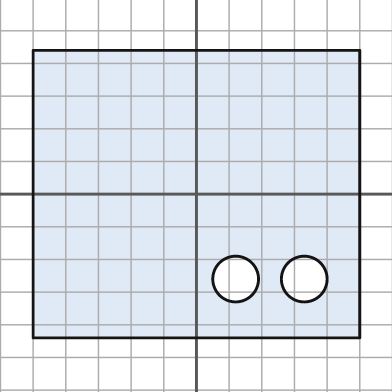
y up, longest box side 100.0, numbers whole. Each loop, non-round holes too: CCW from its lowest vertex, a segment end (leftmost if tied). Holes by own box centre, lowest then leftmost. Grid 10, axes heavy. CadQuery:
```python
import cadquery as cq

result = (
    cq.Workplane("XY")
    .moveTo(-50.0, -44.0)
    .lineTo(50.0, -44.0)
    .lineTo(50.0, 44.0)
    .lineTo(-50.0, 44.0)
    .close()
    .moveTo(12.0, -26.0)
    .circle(7.0)
    .moveTo(33.0, -26.0)
    .circle(7.0)
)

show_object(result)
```